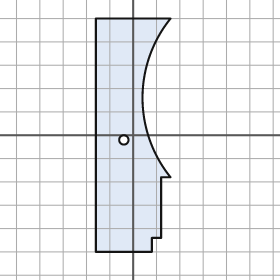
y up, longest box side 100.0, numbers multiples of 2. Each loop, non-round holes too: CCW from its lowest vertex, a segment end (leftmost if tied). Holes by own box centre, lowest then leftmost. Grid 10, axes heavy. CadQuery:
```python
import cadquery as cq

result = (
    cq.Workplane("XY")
    .moveTo(-16.0, -50.0)
    .lineTo(8.0, -50.0)
    .lineTo(8.0, -44.0)
    .lineTo(12.0, -44.0)
    .lineTo(12.0, -18.0)
    .lineTo(16.0, -18.0)
    .threePointArc((4.0, 16.0), (16.0, 50.0))
    .lineTo(-16.0, 50.0)
    .close()
    .moveTo(-4.0, -2.0)
    .circle(2.0)
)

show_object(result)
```